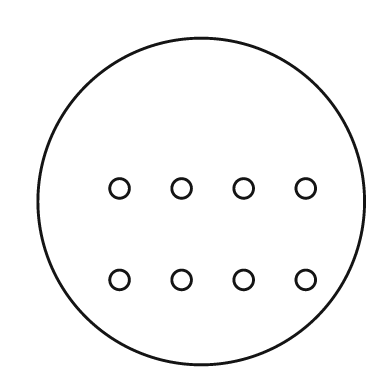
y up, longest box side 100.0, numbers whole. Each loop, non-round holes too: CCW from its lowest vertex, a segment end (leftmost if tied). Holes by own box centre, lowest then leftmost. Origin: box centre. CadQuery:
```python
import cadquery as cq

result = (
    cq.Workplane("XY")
    .moveTo(0.0, 0.0)
    .circle(50.0)
    .moveTo(-25.0, -24.0)
    .circle(3.0)
    .moveTo(-6.0, -24.0)
    .circle(3.0)
    .moveTo(13.0, -24.0)
    .circle(3.0)
    .moveTo(32.0, -24.0)
    .circle(3.0)
    .moveTo(-25.0, 4.0)
    .circle(3.0)
    .moveTo(-6.0, 4.0)
    .circle(3.0)
    .moveTo(13.0, 4.0)
    .circle(3.0)
    .moveTo(32.0, 4.0)
    .circle(3.0)
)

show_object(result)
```